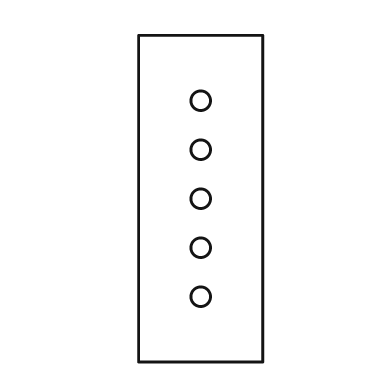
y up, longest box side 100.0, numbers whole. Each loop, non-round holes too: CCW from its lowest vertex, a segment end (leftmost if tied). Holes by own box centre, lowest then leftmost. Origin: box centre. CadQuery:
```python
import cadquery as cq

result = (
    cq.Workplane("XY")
    .moveTo(-19.0, -50.0)
    .lineTo(19.0, -50.0)
    .lineTo(19.0, 50.0)
    .lineTo(-19.0, 50.0)
    .close()
    .moveTo(0.0, -30.0)
    .circle(3.0)
    .moveTo(0.0, -15.0)
    .circle(3.0)
    .moveTo(0.0, 0.0)
    .circle(3.0)
    .moveTo(0.0, 15.0)
    .circle(3.0)
    .moveTo(0.0, 30.0)
    .circle(3.0)
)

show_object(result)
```